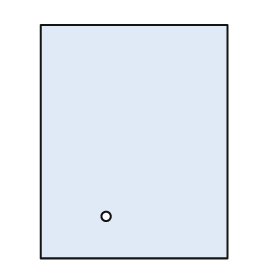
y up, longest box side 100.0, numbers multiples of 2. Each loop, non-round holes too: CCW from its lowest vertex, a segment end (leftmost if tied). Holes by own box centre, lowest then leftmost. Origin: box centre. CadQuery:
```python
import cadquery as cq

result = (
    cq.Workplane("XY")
    .moveTo(-40.0, -50.0)
    .lineTo(40.0, -50.0)
    .lineTo(40.0, 50.0)
    .lineTo(-40.0, 50.0)
    .close()
    .moveTo(-12.0, -32.0)
    .circle(2.0)
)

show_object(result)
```